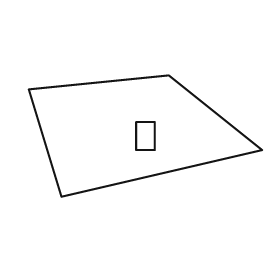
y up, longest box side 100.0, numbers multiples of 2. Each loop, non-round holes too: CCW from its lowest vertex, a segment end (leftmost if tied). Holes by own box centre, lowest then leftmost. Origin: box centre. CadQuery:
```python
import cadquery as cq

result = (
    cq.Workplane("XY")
    .moveTo(-36.0, -26.0)
    .lineTo(50.0, -6.0)
    .lineTo(10.0, 26.0)
    .lineTo(-50.0, 20.0)
    .close()
    .moveTo(-4.0, -6.0)
    .lineTo(4.0, -6.0)
    .lineTo(4.0, 6.0)
    .lineTo(-4.0, 6.0)
    .close()
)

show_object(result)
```